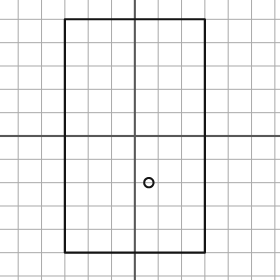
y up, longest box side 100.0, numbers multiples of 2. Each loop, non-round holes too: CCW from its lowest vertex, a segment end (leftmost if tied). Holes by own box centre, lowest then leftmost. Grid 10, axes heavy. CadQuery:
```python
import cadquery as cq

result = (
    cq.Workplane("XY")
    .moveTo(-30.0, -50.0)
    .lineTo(30.0, -50.0)
    .lineTo(30.0, 50.0)
    .lineTo(-30.0, 50.0)
    .close()
    .moveTo(6.0, -20.0)
    .circle(2.0)
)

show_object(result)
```